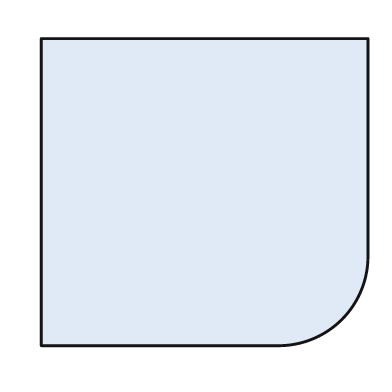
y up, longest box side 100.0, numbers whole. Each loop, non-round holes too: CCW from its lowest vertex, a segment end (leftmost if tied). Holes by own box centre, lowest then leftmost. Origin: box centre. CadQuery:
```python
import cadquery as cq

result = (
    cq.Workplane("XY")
    .moveTo(-50.0, -47.0)
    .lineTo(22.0, -47.0)
    .threePointArc((42.0, -39.0), (50.0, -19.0))
    .lineTo(50.0, 47.0)
    .lineTo(-50.0, 47.0)
    .close()
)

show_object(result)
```